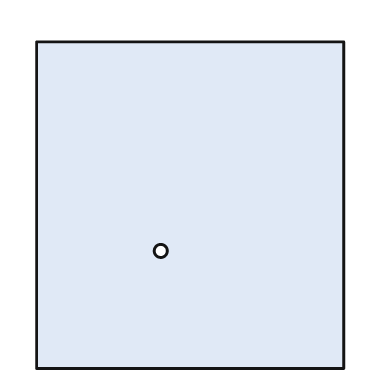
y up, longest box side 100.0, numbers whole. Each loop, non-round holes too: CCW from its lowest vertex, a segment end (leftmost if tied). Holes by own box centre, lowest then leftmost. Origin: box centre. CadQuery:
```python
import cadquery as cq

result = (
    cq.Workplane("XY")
    .moveTo(-47.0, -50.0)
    .lineTo(47.0, -50.0)
    .lineTo(47.0, 50.0)
    .lineTo(-47.0, 50.0)
    .close()
    .moveTo(-9.0, -14.0)
    .circle(2.0)
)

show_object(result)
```